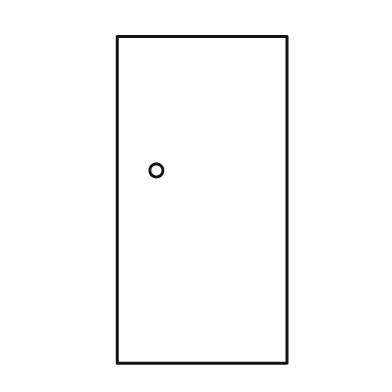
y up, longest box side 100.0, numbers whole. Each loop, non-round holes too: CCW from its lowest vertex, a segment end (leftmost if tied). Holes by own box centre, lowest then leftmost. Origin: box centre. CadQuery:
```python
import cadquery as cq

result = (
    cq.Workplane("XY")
    .moveTo(-26.0, -50.0)
    .lineTo(26.0, -50.0)
    .lineTo(26.0, 50.0)
    .lineTo(-26.0, 50.0)
    .close()
    .moveTo(-14.0, 9.0)
    .circle(2.0)
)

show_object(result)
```